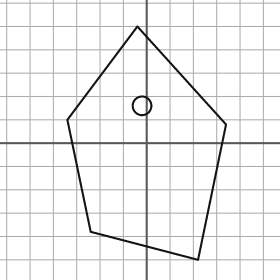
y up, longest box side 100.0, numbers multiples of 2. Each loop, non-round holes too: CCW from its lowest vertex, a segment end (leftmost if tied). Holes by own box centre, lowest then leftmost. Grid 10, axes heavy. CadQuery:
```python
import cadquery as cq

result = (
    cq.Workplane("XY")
    .moveTo(22.0, -50.0)
    .lineTo(34.0, 8.0)
    .lineTo(-4.0, 50.0)
    .lineTo(-34.0, 10.0)
    .lineTo(-24.0, -38.0)
    .close()
    .moveTo(-2.0, 16.0)
    .circle(4.0)
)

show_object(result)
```